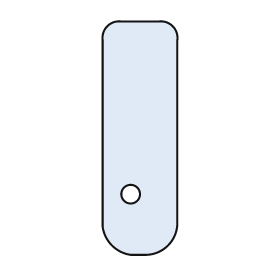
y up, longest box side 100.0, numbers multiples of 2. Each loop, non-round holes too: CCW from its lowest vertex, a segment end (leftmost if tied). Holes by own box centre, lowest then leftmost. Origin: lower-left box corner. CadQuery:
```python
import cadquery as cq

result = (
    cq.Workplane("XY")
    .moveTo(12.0, 0.0)
    .lineTo(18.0, 0.0)
    .threePointArc((28.0, 4.0), (32.0, 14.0))
    .lineTo(32.0, 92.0)
    .threePointArc((30.0, 98.0), (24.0, 100.0))
    .lineTo(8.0, 100.0)
    .threePointArc((2.0, 98.0), (0.0, 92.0))
    .lineTo(0.0, 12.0)
    .threePointArc((4.0, 4.0), (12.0, 0.0))
    .close()
    .moveTo(12.0, 26.0)
    .circle(4.0)
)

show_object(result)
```